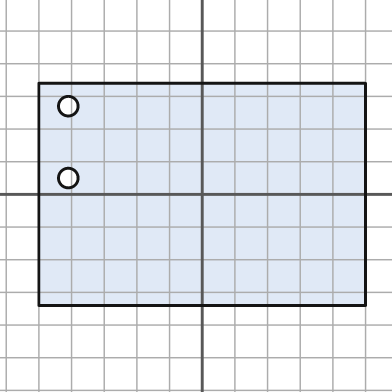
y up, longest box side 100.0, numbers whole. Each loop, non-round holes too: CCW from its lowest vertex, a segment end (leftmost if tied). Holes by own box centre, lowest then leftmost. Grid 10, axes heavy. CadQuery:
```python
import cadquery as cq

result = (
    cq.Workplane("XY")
    .moveTo(-50.0, -34.0)
    .lineTo(50.0, -34.0)
    .lineTo(50.0, 34.0)
    .lineTo(-50.0, 34.0)
    .close()
    .moveTo(-41.0, 5.0)
    .circle(3.0)
    .moveTo(-41.0, 27.0)
    .circle(3.0)
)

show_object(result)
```